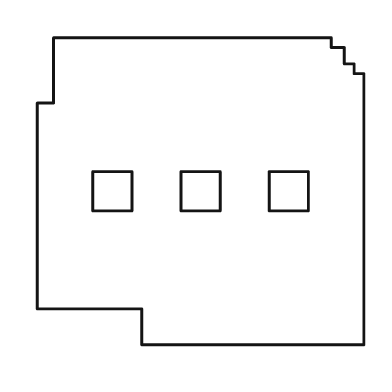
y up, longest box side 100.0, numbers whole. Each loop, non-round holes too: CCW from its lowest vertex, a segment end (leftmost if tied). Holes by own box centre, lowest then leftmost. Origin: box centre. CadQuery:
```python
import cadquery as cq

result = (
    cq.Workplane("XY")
    .moveTo(-18.0, -47.0)
    .lineTo(50.0, -47.0)
    .lineTo(50.0, 36.0)
    .lineTo(47.0, 36.0)
    .lineTo(47.0, 39.0)
    .lineTo(44.0, 39.0)
    .lineTo(44.0, 44.0)
    .lineTo(40.0, 44.0)
    .lineTo(40.0, 47.0)
    .lineTo(-45.0, 47.0)
    .lineTo(-45.0, 27.0)
    .lineTo(-50.0, 27.0)
    .lineTo(-50.0, -36.0)
    .lineTo(-18.0, -36.0)
    .close()
    .moveTo(-33.0, -6.0)
    .lineTo(-21.0, -6.0)
    .lineTo(-21.0, 6.0)
    .lineTo(-33.0, 6.0)
    .close()
    .moveTo(-6.0, -6.0)
    .lineTo(6.0, -6.0)
    .lineTo(6.0, 6.0)
    .lineTo(-6.0, 6.0)
    .close()
    .moveTo(21.0, -6.0)
    .lineTo(33.0, -6.0)
    .lineTo(33.0, 6.0)
    .lineTo(21.0, 6.0)
    .close()
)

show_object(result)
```